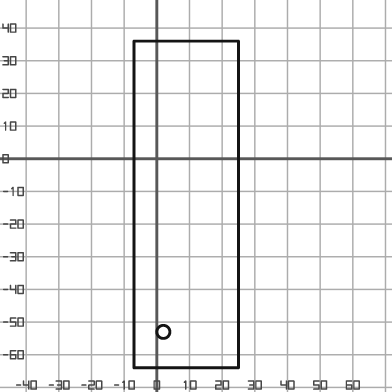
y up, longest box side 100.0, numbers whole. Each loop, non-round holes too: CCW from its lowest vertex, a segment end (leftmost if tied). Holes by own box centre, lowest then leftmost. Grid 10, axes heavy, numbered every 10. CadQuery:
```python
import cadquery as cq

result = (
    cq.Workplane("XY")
    .moveTo(-7.0, -64.0)
    .lineTo(25.0, -64.0)
    .lineTo(25.0, 36.0)
    .lineTo(-7.0, 36.0)
    .close()
    .moveTo(2.0, -53.0)
    .circle(2.0)
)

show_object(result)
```